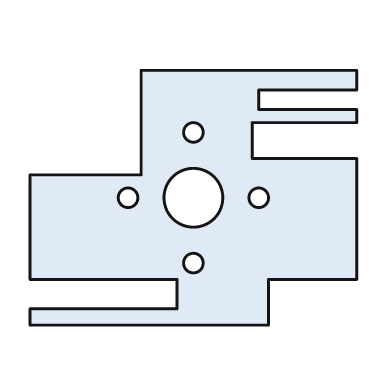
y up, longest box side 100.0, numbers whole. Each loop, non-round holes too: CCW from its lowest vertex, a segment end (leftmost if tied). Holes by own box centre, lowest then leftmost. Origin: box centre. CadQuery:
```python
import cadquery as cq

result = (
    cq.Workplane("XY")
    .moveTo(-50.0, -39.0)
    .lineTo(23.0, -39.0)
    .lineTo(23.0, -25.0)
    .lineTo(50.0, -25.0)
    .lineTo(50.0, 12.0)
    .lineTo(18.0, 12.0)
    .lineTo(18.0, 23.0)
    .lineTo(50.0, 23.0)
    .lineTo(50.0, 27.0)
    .lineTo(20.0, 27.0)
    .lineTo(20.0, 33.0)
    .lineTo(50.0, 33.0)
    .lineTo(50.0, 39.0)
    .lineTo(-16.0, 39.0)
    .lineTo(-16.0, 7.0)
    .lineTo(-50.0, 7.0)
    .lineTo(-50.0, -25.0)
    .lineTo(-5.0, -25.0)
    .lineTo(-5.0, -34.0)
    .lineTo(-50.0, -34.0)
    .close()
    .moveTo(0.0, -20.0)
    .circle(3.0)
    .moveTo(-20.0, 0.0)
    .circle(3.0)
    .moveTo(0.0, 0.0)
    .circle(9.0)
    .moveTo(20.0, 0.0)
    .circle(3.0)
    .moveTo(0.0, 20.0)
    .circle(3.0)
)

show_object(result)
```